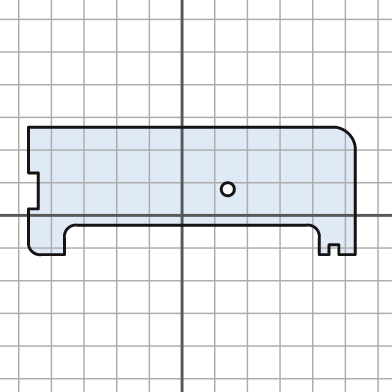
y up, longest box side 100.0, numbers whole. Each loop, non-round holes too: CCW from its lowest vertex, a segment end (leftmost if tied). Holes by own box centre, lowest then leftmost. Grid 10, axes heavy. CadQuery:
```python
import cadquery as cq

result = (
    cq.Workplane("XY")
    .moveTo(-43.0, -12.0)
    .lineTo(-36.0, -12.0)
    .lineTo(-36.0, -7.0)
    .threePointArc((-35.0, -4.0), (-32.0, -3.0))
    .lineTo(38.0, -3.0)
    .threePointArc((41.0, -4.0), (42.0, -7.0))
    .lineTo(42.0, -12.0)
    .lineTo(45.0, -12.0)
    .lineTo(45.0, -9.0)
    .lineTo(48.0, -9.0)
    .lineTo(48.0, -12.0)
    .lineTo(53.0, -12.0)
    .lineTo(53.0, 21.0)
    .threePointArc((51.0, 25.0), (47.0, 27.0))
    .lineTo(-47.0, 27.0)
    .lineTo(-47.0, 13.0)
    .lineTo(-44.0, 13.0)
    .lineTo(-44.0, 2.0)
    .lineTo(-47.0, 2.0)
    .lineTo(-47.0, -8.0)
    .threePointArc((-46.0, -11.0), (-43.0, -12.0))
    .close()
    .moveTo(14.0, 8.0)
    .circle(2.0)
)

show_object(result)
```